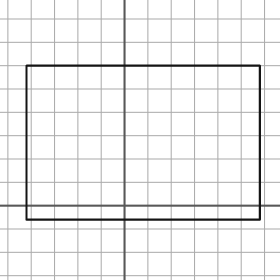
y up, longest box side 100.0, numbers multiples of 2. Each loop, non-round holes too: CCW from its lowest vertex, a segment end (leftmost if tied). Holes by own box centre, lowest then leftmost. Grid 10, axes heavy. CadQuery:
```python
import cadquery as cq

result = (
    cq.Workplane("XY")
    .moveTo(-42.0, -6.0)
    .lineTo(58.0, -6.0)
    .lineTo(58.0, 60.0)
    .lineTo(-42.0, 60.0)
    .close()
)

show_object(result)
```